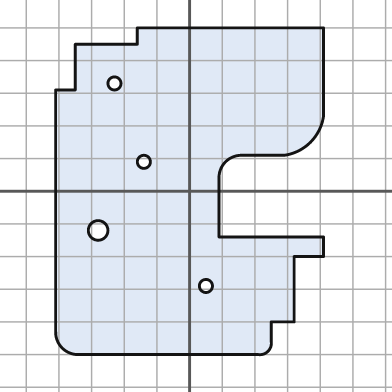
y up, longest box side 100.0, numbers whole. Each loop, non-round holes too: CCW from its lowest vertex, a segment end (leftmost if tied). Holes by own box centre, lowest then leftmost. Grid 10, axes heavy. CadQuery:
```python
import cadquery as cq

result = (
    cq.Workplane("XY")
    .moveTo(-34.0, -50.0)
    .lineTo(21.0, -50.0)
    .threePointArc((24.0, -49.0), (25.0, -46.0))
    .lineTo(25.0, -40.0)
    .lineTo(32.0, -40.0)
    .lineTo(32.0, -20.0)
    .lineTo(41.0, -20.0)
    .lineTo(41.0, -14.0)
    .lineTo(9.0, -14.0)
    .lineTo(9.0, 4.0)
    .threePointArc((11.0, 9.0), (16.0, 11.0))
    .lineTo(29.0, 11.0)
    .threePointArc((37.0, 15.0), (41.0, 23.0))
    .lineTo(41.0, 50.0)
    .lineTo(-16.0, 50.0)
    .lineTo(-16.0, 45.0)
    .lineTo(-35.0, 45.0)
    .lineTo(-35.0, 31.0)
    .lineTo(-41.0, 31.0)
    .lineTo(-41.0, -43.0)
    .threePointArc((-39.0, -48.0), (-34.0, -50.0))
    .close()
    .moveTo(5.0, -29.0)
    .circle(2.0)
    .moveTo(-28.0, -12.0)
    .circle(3.0)
    .moveTo(-14.0, 9.0)
    .circle(2.0)
    .moveTo(-23.0, 33.0)
    .circle(2.0)
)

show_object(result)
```